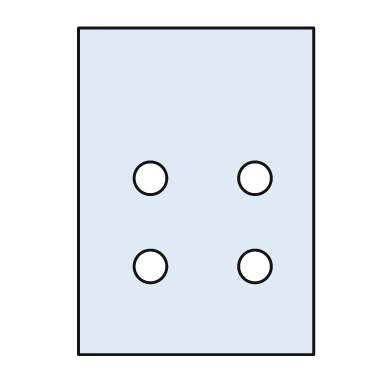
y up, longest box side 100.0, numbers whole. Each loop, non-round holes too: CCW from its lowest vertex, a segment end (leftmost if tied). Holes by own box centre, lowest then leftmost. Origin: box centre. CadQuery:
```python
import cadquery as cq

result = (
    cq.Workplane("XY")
    .moveTo(-36.0, -50.0)
    .lineTo(36.0, -50.0)
    .lineTo(36.0, 50.0)
    .lineTo(-36.0, 50.0)
    .close()
    .moveTo(-14.0, -23.0)
    .circle(5.0)
    .moveTo(18.0, -23.0)
    .circle(5.0)
    .moveTo(-14.0, 4.0)
    .circle(5.0)
    .moveTo(18.0, 4.0)
    .circle(5.0)
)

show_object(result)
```